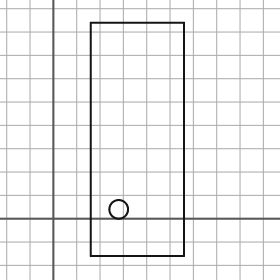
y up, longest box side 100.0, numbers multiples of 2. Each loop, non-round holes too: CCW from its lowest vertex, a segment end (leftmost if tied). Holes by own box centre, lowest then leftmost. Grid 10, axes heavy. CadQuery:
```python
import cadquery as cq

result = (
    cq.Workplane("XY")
    .moveTo(16.0, -16.0)
    .lineTo(56.0, -16.0)
    .lineTo(56.0, 84.0)
    .lineTo(16.0, 84.0)
    .close()
    .moveTo(28.0, 4.0)
    .circle(4.0)
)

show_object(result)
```